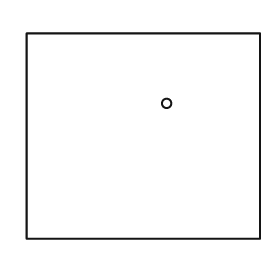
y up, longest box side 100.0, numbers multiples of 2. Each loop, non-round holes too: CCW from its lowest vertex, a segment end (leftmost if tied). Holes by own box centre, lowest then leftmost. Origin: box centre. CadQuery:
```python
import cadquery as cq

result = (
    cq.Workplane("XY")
    .moveTo(-50.0, -44.0)
    .lineTo(50.0, -44.0)
    .lineTo(50.0, 44.0)
    .lineTo(-50.0, 44.0)
    .close()
    .moveTo(10.0, 14.0)
    .circle(2.0)
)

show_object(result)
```